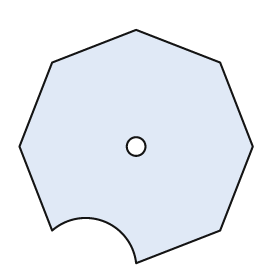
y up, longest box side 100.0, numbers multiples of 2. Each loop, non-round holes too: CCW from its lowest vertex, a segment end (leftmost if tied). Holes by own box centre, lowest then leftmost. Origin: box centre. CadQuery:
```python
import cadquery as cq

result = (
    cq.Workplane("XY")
    .moveTo(0.0, -50.0)
    .lineTo(36.0, -36.0)
    .lineTo(50.0, 0.0)
    .lineTo(36.0, 36.0)
    .lineTo(0.0, 50.0)
    .lineTo(-36.0, 36.0)
    .lineTo(-50.0, 0.0)
    .lineTo(-36.0, -36.0)
    .threePointArc((-14.0, -32.0), (0.0, -50.0))
    .close()
    .moveTo(0.0, 0.0)
    .circle(4.0)
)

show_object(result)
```